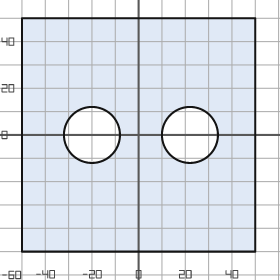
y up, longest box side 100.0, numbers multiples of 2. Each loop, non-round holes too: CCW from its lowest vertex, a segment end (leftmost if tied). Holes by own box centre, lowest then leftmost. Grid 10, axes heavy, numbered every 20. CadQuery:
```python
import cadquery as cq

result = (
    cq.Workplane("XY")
    .moveTo(-50.0, -50.0)
    .lineTo(50.0, -50.0)
    .lineTo(50.0, 50.0)
    .lineTo(-50.0, 50.0)
    .close()
    .moveTo(-20.0, 0.0)
    .circle(12.0)
    .moveTo(22.0, 0.0)
    .circle(12.0)
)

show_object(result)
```